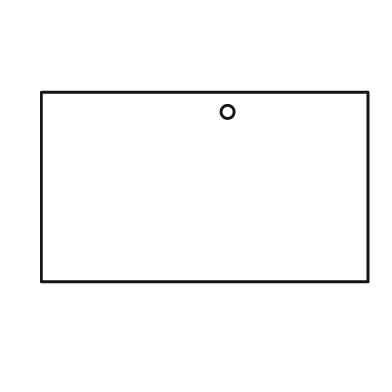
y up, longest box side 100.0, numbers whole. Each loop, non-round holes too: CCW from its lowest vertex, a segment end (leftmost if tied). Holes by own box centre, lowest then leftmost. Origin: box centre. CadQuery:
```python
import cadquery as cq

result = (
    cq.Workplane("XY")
    .moveTo(-50.0, -29.0)
    .lineTo(50.0, -29.0)
    .lineTo(50.0, 29.0)
    .lineTo(-50.0, 29.0)
    .close()
    .moveTo(7.0, 23.0)
    .circle(2.0)
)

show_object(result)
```